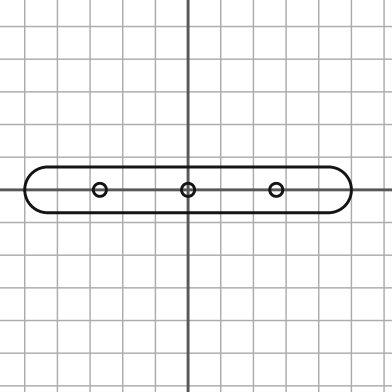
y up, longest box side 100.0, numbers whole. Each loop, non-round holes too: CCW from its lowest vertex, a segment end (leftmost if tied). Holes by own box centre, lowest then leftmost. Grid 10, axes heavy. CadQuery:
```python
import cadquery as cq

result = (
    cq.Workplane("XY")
    .moveTo(-43.0, -7.0)
    .lineTo(43.0, -7.0)
    .threePointArc((50.0, 0.0), (43.0, 7.0))
    .lineTo(-43.0, 7.0)
    .threePointArc((-50.0, 0.0), (-43.0, -7.0))
    .close()
    .moveTo(-27.0, 0.0)
    .circle(2.0)
    .moveTo(0.0, 0.0)
    .circle(2.0)
    .moveTo(27.0, 0.0)
    .circle(2.0)
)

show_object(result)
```